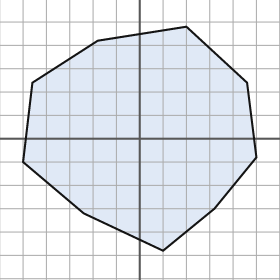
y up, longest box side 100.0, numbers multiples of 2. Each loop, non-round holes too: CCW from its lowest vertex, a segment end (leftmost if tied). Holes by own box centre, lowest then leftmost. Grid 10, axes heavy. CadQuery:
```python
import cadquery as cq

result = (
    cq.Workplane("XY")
    .moveTo(10.0, -48.0)
    .lineTo(32.0, -30.0)
    .lineTo(50.0, -8.0)
    .lineTo(46.0, 24.0)
    .lineTo(20.0, 48.0)
    .lineTo(-18.0, 42.0)
    .lineTo(-46.0, 24.0)
    .lineTo(-50.0, -10.0)
    .lineTo(-24.0, -32.0)
    .close()
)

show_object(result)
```